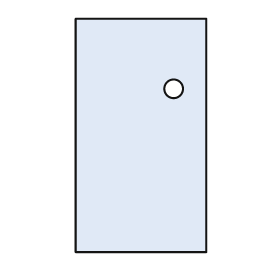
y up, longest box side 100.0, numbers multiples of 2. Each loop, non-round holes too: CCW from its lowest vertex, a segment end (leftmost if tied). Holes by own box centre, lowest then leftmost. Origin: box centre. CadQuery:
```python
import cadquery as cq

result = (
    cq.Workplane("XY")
    .moveTo(-28.0, -50.0)
    .lineTo(28.0, -50.0)
    .lineTo(28.0, 50.0)
    .lineTo(-28.0, 50.0)
    .close()
    .moveTo(14.0, 20.0)
    .circle(4.0)
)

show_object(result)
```